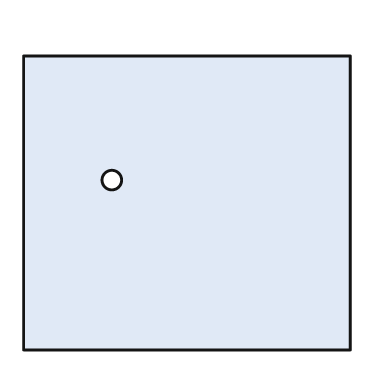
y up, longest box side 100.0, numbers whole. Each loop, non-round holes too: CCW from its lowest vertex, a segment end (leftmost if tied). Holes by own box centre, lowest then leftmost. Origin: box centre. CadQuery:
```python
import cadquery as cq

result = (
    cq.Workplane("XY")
    .moveTo(-50.0, -45.0)
    .lineTo(50.0, -45.0)
    .lineTo(50.0, 45.0)
    .lineTo(-50.0, 45.0)
    .close()
    .moveTo(-23.0, 7.0)
    .circle(3.0)
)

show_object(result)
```